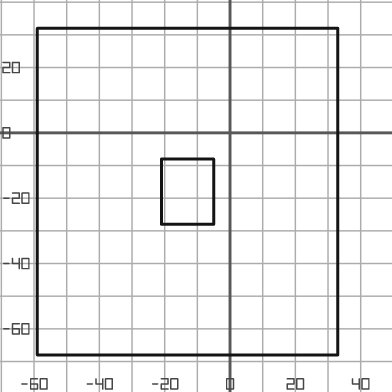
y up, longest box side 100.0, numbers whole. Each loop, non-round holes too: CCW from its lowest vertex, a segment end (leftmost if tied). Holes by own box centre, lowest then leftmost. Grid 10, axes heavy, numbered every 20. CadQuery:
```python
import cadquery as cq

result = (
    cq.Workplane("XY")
    .moveTo(-59.0, -68.0)
    .lineTo(33.0, -68.0)
    .lineTo(33.0, 32.0)
    .lineTo(-59.0, 32.0)
    .close()
    .moveTo(-21.0, -28.0)
    .lineTo(-5.0, -28.0)
    .lineTo(-5.0, -8.0)
    .lineTo(-21.0, -8.0)
    .close()
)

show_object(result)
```